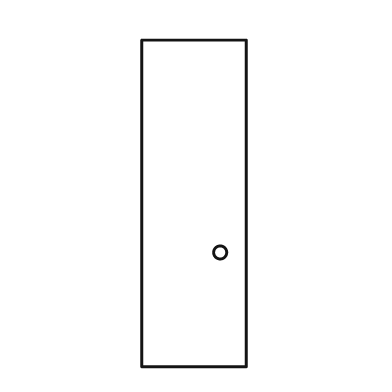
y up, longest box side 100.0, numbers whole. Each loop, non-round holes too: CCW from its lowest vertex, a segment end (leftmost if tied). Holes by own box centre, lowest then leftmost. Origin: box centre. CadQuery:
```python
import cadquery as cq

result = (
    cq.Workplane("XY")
    .moveTo(-16.0, -50.0)
    .lineTo(16.0, -50.0)
    .lineTo(16.0, 50.0)
    .lineTo(-16.0, 50.0)
    .close()
    .moveTo(8.0, -15.0)
    .circle(2.0)
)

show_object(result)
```